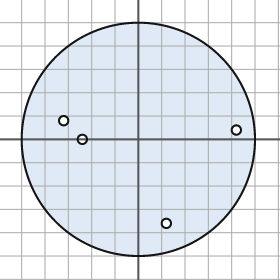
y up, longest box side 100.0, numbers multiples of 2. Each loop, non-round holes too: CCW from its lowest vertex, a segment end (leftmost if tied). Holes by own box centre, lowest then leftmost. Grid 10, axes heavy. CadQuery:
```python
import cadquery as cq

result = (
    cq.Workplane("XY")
    .moveTo(0.0, 0.0)
    .circle(50.0)
    .moveTo(12.0, -36.0)
    .circle(2.0)
    .moveTo(-24.0, 0.0)
    .circle(2.0)
    .moveTo(42.0, 4.0)
    .circle(2.0)
    .moveTo(-32.0, 8.0)
    .circle(2.0)
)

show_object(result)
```